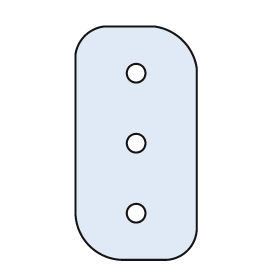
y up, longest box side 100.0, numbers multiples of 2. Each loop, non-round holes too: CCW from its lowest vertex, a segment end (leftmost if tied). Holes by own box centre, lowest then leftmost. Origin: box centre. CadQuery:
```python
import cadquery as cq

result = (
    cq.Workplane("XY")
    .moveTo(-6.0, -50.0)
    .lineTo(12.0, -50.0)
    .threePointArc((22.0, -46.0), (26.0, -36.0))
    .lineTo(26.0, 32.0)
    .threePointArc((20.0, 44.0), (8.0, 50.0))
    .lineTo(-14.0, 50.0)
    .threePointArc((-22.0, 46.0), (-26.0, 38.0))
    .lineTo(-26.0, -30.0)
    .threePointArc((-20.0, -44.0), (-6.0, -50.0))
    .close()
    .moveTo(0.0, -30.0)
    .circle(4.0)
    .moveTo(0.0, 0.0)
    .circle(4.0)
    .moveTo(0.0, 30.0)
    .circle(4.0)
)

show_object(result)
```